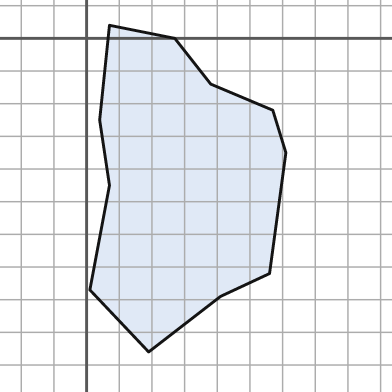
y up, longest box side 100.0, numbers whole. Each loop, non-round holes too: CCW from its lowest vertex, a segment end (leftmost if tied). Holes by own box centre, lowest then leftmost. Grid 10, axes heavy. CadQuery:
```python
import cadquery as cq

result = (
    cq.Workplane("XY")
    .moveTo(19.0, -96.0)
    .lineTo(41.0, -79.0)
    .lineTo(56.0, -72.0)
    .lineTo(61.0, -35.0)
    .lineTo(57.0, -22.0)
    .lineTo(38.0, -14.0)
    .lineTo(27.0, 0.0)
    .lineTo(7.0, 4.0)
    .lineTo(4.0, -25.0)
    .lineTo(7.0, -45.0)
    .lineTo(1.0, -77.0)
    .close()
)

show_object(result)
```